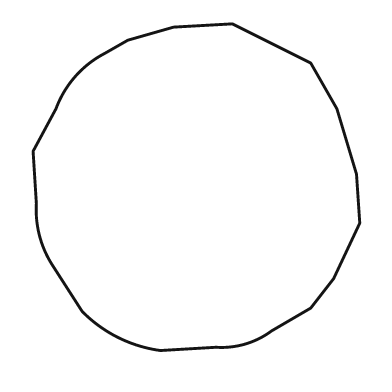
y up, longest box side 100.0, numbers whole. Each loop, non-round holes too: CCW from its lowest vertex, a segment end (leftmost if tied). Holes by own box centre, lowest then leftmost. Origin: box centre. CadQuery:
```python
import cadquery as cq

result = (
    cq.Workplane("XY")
    .moveTo(-11.0, -50.0)
    .lineTo(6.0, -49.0)
    .threePointArc((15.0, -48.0), (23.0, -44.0))
    .lineTo(35.0, -37.0)
    .lineTo(42.0, -28.0)
    .lineTo(50.0, -11.0)
    .lineTo(49.0, 4.0)
    .lineTo(43.0, 24.0)
    .lineTo(35.0, 38.0)
    .lineTo(11.0, 50.0)
    .lineTo(-7.0, 49.0)
    .lineTo(-21.0, 45.0)
    .lineTo(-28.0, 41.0)
    .threePointArc((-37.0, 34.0), (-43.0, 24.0))
    .lineTo(-50.0, 11.0)
    .lineTo(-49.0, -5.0)
    .threePointArc((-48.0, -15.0), (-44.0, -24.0))
    .lineTo(-35.0, -38.0)
    .threePointArc((-24.0, -46.0), (-11.0, -50.0))
    .close()
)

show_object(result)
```